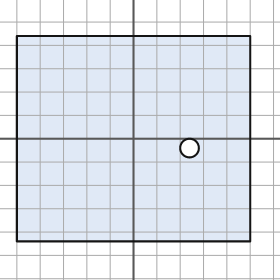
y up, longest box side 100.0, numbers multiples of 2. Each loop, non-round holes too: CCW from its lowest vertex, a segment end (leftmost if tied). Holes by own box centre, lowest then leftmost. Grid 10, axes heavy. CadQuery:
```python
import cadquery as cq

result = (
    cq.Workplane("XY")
    .moveTo(-50.0, -44.0)
    .lineTo(50.0, -44.0)
    .lineTo(50.0, 44.0)
    .lineTo(-50.0, 44.0)
    .close()
    .moveTo(24.0, -4.0)
    .circle(4.0)
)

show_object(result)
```